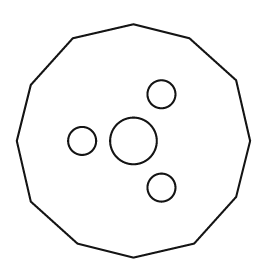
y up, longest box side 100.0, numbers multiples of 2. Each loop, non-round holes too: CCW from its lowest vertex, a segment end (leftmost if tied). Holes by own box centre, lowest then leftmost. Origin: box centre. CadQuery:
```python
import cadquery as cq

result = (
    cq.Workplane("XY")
    .moveTo(0.0, -50.0)
    .lineTo(26.0, -44.0)
    .lineTo(44.0, -24.0)
    .lineTo(50.0, 0.0)
    .lineTo(44.0, 26.0)
    .lineTo(24.0, 44.0)
    .lineTo(0.0, 50.0)
    .lineTo(-26.0, 44.0)
    .lineTo(-44.0, 24.0)
    .lineTo(-50.0, 0.0)
    .lineTo(-44.0, -26.0)
    .lineTo(-24.0, -44.0)
    .close()
    .moveTo(12.0, -20.0)
    .circle(6.0)
    .moveTo(-22.0, 0.0)
    .circle(6.0)
    .moveTo(0.0, 0.0)
    .circle(10.0)
    .moveTo(12.0, 20.0)
    .circle(6.0)
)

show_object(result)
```